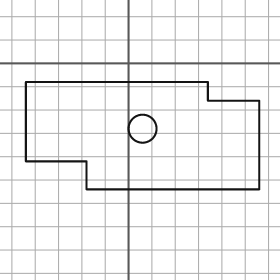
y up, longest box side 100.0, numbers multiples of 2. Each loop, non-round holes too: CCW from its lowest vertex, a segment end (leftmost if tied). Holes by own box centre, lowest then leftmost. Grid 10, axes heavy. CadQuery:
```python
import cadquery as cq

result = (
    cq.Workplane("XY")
    .moveTo(-18.0, -54.0)
    .lineTo(56.0, -54.0)
    .lineTo(56.0, -16.0)
    .lineTo(34.0, -16.0)
    .lineTo(34.0, -8.0)
    .lineTo(-44.0, -8.0)
    .lineTo(-44.0, -42.0)
    .lineTo(-18.0, -42.0)
    .close()
    .moveTo(6.0, -28.0)
    .circle(6.0)
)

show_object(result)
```